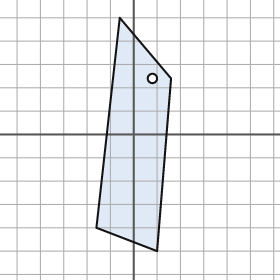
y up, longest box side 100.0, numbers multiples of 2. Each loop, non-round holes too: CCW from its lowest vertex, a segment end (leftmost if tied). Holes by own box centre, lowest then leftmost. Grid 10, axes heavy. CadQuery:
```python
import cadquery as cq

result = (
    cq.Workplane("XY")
    .moveTo(10.0, -50.0)
    .lineTo(16.0, 24.0)
    .lineTo(-6.0, 50.0)
    .lineTo(-16.0, -40.0)
    .close()
    .moveTo(8.0, 24.0)
    .circle(2.0)
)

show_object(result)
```